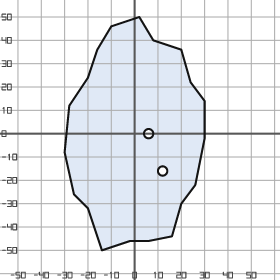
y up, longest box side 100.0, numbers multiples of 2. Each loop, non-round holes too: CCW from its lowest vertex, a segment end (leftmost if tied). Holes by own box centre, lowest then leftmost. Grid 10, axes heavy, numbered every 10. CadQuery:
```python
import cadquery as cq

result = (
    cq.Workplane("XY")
    .moveTo(-14.0, -50.0)
    .lineTo(-2.0, -46.0)
    .lineTo(6.0, -46.0)
    .lineTo(16.0, -44.0)
    .lineTo(20.0, -30.0)
    .lineTo(26.0, -22.0)
    .lineTo(30.0, -2.0)
    .lineTo(30.0, 14.0)
    .lineTo(24.0, 22.0)
    .lineTo(20.0, 36.0)
    .lineTo(8.0, 40.0)
    .lineTo(2.0, 50.0)
    .lineTo(-10.0, 46.0)
    .lineTo(-16.0, 36.0)
    .lineTo(-20.0, 24.0)
    .lineTo(-28.0, 12.0)
    .lineTo(-30.0, -8.0)
    .lineTo(-26.0, -26.0)
    .lineTo(-20.0, -32.0)
    .close()
    .moveTo(12.0, -16.0)
    .circle(2.0)
    .moveTo(6.0, 0.0)
    .circle(2.0)
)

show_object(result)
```